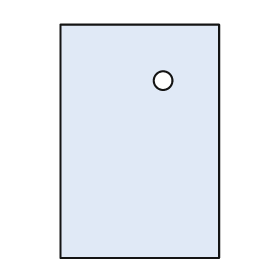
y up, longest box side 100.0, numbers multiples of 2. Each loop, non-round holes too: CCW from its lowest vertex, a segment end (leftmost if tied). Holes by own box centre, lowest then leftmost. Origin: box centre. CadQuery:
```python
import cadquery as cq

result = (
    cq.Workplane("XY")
    .moveTo(-34.0, -50.0)
    .lineTo(34.0, -50.0)
    .lineTo(34.0, 50.0)
    .lineTo(-34.0, 50.0)
    .close()
    .moveTo(10.0, 26.0)
    .circle(4.0)
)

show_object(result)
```